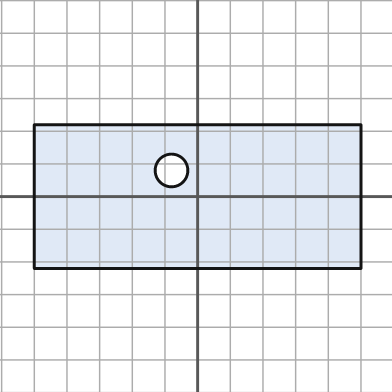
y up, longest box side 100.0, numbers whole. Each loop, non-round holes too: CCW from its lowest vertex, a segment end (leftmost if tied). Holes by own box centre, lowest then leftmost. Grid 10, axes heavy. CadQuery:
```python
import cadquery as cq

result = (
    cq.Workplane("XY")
    .moveTo(-50.0, -22.0)
    .lineTo(50.0, -22.0)
    .lineTo(50.0, 22.0)
    .lineTo(-50.0, 22.0)
    .close()
    .moveTo(-8.0, 8.0)
    .circle(5.0)
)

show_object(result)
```